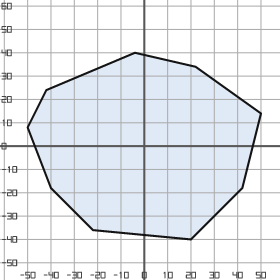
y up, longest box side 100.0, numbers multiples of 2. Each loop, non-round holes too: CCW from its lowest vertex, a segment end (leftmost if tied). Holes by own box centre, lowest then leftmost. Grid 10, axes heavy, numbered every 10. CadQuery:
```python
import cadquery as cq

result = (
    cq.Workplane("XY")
    .moveTo(20.0, -40.0)
    .lineTo(42.0, -18.0)
    .lineTo(50.0, 14.0)
    .lineTo(22.0, 34.0)
    .lineTo(-4.0, 40.0)
    .lineTo(-42.0, 24.0)
    .lineTo(-50.0, 8.0)
    .lineTo(-40.0, -18.0)
    .lineTo(-22.0, -36.0)
    .close()
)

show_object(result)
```